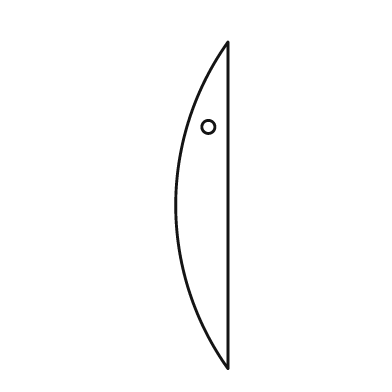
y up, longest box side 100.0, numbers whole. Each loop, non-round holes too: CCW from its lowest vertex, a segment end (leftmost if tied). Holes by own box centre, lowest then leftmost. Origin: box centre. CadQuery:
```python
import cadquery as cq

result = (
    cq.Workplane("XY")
    .moveTo(8.0, -50.0)
    .lineTo(8.0, 50.0)
    .threePointArc((-8.0, 0.0), (8.0, -50.0))
    .close()
    .moveTo(2.0, 24.0)
    .circle(2.0)
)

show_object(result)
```